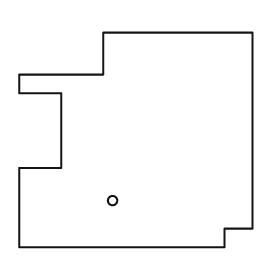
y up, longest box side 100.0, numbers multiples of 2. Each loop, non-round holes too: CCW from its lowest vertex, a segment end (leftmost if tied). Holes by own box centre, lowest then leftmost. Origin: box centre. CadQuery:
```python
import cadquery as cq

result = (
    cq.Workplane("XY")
    .moveTo(-50.0, -46.0)
    .lineTo(38.0, -46.0)
    .lineTo(38.0, -38.0)
    .lineTo(50.0, -38.0)
    .lineTo(50.0, 46.0)
    .lineTo(-14.0, 46.0)
    .lineTo(-14.0, 28.0)
    .lineTo(-50.0, 28.0)
    .lineTo(-50.0, 20.0)
    .lineTo(-32.0, 20.0)
    .lineTo(-32.0, -12.0)
    .lineTo(-50.0, -12.0)
    .close()
    .moveTo(-10.0, -26.0)
    .circle(2.0)
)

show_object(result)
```